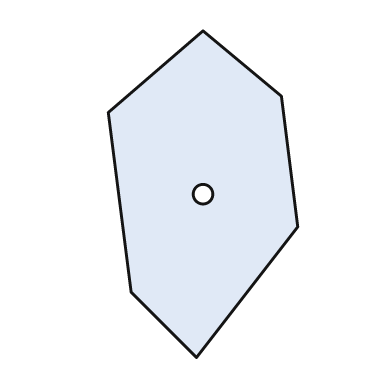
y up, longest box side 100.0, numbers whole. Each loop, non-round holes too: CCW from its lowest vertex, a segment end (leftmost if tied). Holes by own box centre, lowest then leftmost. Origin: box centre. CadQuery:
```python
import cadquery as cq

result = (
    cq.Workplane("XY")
    .moveTo(-2.0, -50.0)
    .lineTo(29.0, -10.0)
    .lineTo(24.0, 30.0)
    .lineTo(0.0, 50.0)
    .lineTo(-29.0, 25.0)
    .lineTo(-22.0, -30.0)
    .close()
    .moveTo(0.0, 0.0)
    .circle(3.0)
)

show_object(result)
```